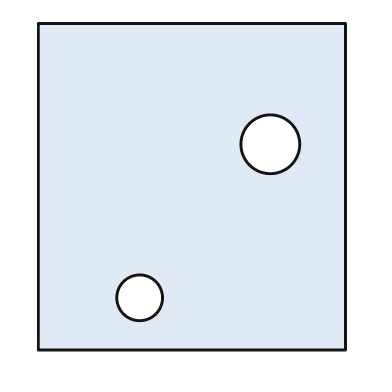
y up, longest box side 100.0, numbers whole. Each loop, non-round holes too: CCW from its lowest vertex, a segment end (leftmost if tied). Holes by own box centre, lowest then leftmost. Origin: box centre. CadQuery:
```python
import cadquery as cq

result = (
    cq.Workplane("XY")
    .moveTo(-47.0, -50.0)
    .lineTo(47.0, -50.0)
    .lineTo(47.0, 50.0)
    .lineTo(-47.0, 50.0)
    .close()
    .moveTo(-16.0, -34.0)
    .circle(7.0)
    .moveTo(24.0, 13.0)
    .circle(9.0)
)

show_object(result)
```